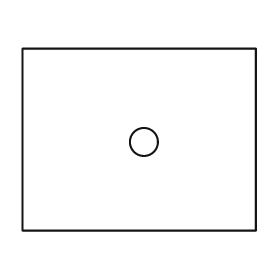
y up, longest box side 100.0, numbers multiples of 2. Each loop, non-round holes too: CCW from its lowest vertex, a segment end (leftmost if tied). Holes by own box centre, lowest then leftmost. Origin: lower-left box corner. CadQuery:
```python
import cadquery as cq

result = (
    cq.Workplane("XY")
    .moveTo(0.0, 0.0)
    .lineTo(100.0, 0.0)
    .lineTo(100.0, 78.0)
    .lineTo(0.0, 78.0)
    .close()
    .moveTo(52.0, 38.0)
    .circle(6.0)
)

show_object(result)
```